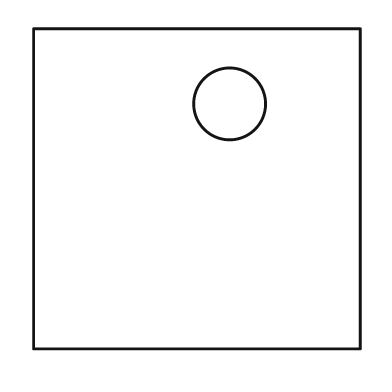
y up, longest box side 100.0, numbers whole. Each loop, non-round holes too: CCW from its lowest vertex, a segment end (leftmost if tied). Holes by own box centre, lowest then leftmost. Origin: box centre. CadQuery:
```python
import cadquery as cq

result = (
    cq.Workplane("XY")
    .moveTo(-50.0, -49.0)
    .lineTo(50.0, -49.0)
    .lineTo(50.0, 49.0)
    .lineTo(-50.0, 49.0)
    .close()
    .moveTo(10.0, 26.0)
    .circle(11.0)
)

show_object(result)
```